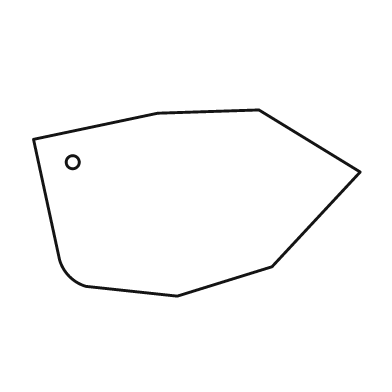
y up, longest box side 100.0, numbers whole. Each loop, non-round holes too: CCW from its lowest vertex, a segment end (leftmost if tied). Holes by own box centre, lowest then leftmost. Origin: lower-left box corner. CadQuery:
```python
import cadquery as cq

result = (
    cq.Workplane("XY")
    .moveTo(44.0, 0.0)
    .lineTo(73.0, 9.0)
    .lineTo(100.0, 38.0)
    .lineTo(69.0, 57.0)
    .lineTo(38.0, 56.0)
    .lineTo(0.0, 48.0)
    .lineTo(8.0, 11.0)
    .threePointArc((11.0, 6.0), (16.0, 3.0))
    .close()
    .moveTo(12.0, 41.0)
    .circle(2.0)
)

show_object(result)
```